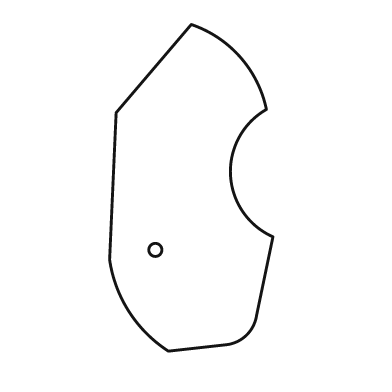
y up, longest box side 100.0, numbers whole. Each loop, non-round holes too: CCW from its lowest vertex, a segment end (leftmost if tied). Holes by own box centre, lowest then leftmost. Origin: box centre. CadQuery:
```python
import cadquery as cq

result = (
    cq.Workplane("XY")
    .moveTo(-7.0, -50.0)
    .lineTo(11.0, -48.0)
    .threePointArc((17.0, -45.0), (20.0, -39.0))
    .lineTo(25.0, -15.0)
    .threePointArc((12.0, 4.0), (23.0, 24.0))
    .threePointArc((15.0, 40.0), (0.0, 50.0))
    .lineTo(-23.0, 23.0)
    .lineTo(-25.0, -22.0)
    .threePointArc((-19.0, -38.0), (-7.0, -50.0))
    .close()
    .moveTo(-11.0, -19.0)
    .circle(2.0)
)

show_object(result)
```